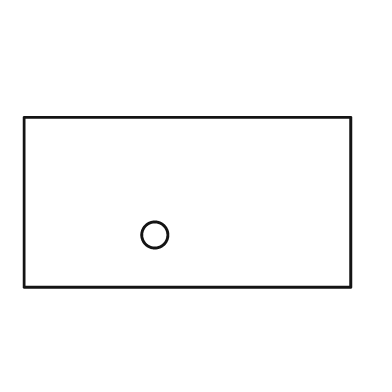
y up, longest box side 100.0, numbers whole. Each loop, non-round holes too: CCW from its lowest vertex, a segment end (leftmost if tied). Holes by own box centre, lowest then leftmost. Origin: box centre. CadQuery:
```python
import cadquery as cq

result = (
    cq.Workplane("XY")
    .moveTo(-50.0, -26.0)
    .lineTo(50.0, -26.0)
    .lineTo(50.0, 26.0)
    .lineTo(-50.0, 26.0)
    .close()
    .moveTo(-10.0, -10.0)
    .circle(4.0)
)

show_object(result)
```